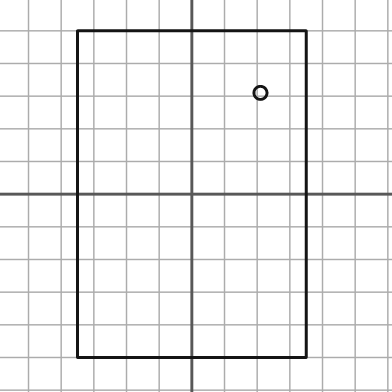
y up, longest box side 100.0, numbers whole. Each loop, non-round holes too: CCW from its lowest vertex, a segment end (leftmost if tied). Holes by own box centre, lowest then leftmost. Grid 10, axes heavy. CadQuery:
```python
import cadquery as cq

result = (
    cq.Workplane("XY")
    .moveTo(-35.0, -50.0)
    .lineTo(35.0, -50.0)
    .lineTo(35.0, 50.0)
    .lineTo(-35.0, 50.0)
    .close()
    .moveTo(21.0, 31.0)
    .circle(2.0)
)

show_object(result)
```